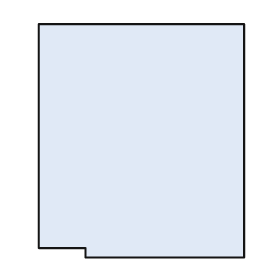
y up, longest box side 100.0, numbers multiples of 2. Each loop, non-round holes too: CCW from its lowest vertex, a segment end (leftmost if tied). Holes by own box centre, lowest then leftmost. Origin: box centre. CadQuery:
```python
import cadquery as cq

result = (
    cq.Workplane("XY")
    .moveTo(-24.0, -50.0)
    .lineTo(44.0, -50.0)
    .lineTo(44.0, 50.0)
    .lineTo(-44.0, 50.0)
    .lineTo(-44.0, -46.0)
    .lineTo(-24.0, -46.0)
    .close()
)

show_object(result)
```